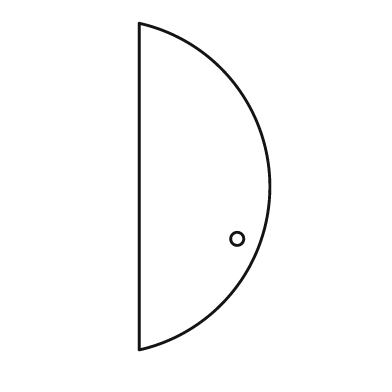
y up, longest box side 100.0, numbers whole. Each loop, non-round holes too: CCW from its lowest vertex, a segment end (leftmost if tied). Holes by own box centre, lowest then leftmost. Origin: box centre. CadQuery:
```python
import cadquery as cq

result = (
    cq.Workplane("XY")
    .moveTo(-20.0, -50.0)
    .threePointArc((20.0, 0.0), (-20.0, 50.0))
    .close()
    .moveTo(10.0, -16.0)
    .circle(2.0)
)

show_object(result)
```